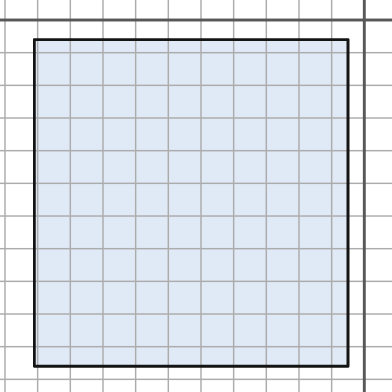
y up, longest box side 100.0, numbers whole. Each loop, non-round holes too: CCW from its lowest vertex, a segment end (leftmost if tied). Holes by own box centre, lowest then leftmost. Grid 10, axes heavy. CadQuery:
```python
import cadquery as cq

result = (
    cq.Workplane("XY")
    .moveTo(-101.0, -106.0)
    .lineTo(-5.0, -106.0)
    .lineTo(-5.0, -6.0)
    .lineTo(-101.0, -6.0)
    .close()
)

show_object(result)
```